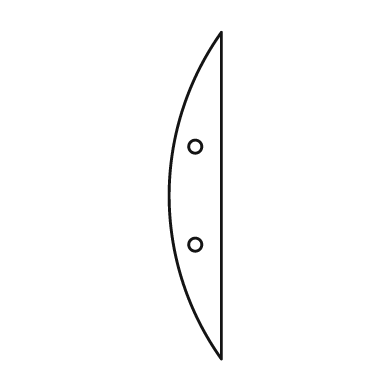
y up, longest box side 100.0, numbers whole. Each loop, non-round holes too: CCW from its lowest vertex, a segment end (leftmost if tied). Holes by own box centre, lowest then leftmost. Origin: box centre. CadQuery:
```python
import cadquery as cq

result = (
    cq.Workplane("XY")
    .moveTo(8.0, -50.0)
    .lineTo(8.0, 50.0)
    .threePointArc((-8.0, 0.0), (8.0, -50.0))
    .close()
    .moveTo(0.0, -15.0)
    .circle(2.0)
    .moveTo(0.0, 15.0)
    .circle(2.0)
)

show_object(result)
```